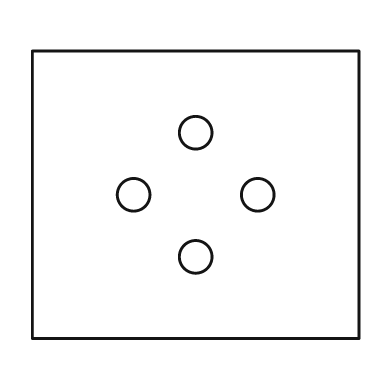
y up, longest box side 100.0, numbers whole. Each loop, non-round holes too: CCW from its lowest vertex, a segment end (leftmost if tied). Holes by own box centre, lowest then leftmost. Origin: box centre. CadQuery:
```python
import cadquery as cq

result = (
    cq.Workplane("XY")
    .moveTo(-50.0, -44.0)
    .lineTo(50.0, -44.0)
    .lineTo(50.0, 44.0)
    .lineTo(-50.0, 44.0)
    .close()
    .moveTo(0.0, -19.0)
    .circle(5.0)
    .moveTo(-19.0, 0.0)
    .circle(5.0)
    .moveTo(19.0, 0.0)
    .circle(5.0)
    .moveTo(0.0, 19.0)
    .circle(5.0)
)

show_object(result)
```